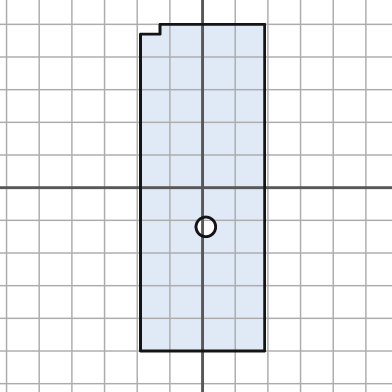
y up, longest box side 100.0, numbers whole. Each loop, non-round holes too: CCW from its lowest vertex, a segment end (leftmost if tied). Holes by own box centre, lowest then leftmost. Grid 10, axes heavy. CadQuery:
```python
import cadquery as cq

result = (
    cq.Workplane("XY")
    .moveTo(-19.0, -50.0)
    .lineTo(19.0, -50.0)
    .lineTo(19.0, 50.0)
    .lineTo(-13.0, 50.0)
    .lineTo(-13.0, 47.0)
    .lineTo(-19.0, 47.0)
    .close()
    .moveTo(1.0, -12.0)
    .circle(3.0)
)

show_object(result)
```